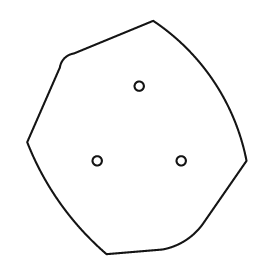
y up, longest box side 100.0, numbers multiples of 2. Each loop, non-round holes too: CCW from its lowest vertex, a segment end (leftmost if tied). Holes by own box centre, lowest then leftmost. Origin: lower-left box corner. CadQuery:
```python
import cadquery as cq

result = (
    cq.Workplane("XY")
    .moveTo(34.0, 0.0)
    .lineTo(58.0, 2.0)
    .threePointArc((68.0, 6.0), (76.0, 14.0))
    .lineTo(94.0, 40.0)
    .threePointArc((80.0, 74.0), (54.0, 100.0))
    .lineTo(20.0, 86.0)
    .threePointArc((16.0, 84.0), (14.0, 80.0))
    .lineTo(0.0, 48.0)
    .threePointArc((14.0, 22.0), (34.0, 0.0))
    .close()
    .moveTo(30.0, 40.0)
    .circle(2.0)
    .moveTo(66.0, 40.0)
    .circle(2.0)
    .moveTo(48.0, 72.0)
    .circle(2.0)
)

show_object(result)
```